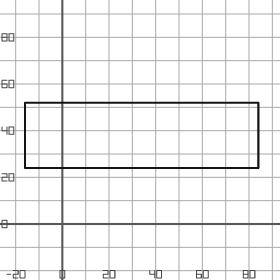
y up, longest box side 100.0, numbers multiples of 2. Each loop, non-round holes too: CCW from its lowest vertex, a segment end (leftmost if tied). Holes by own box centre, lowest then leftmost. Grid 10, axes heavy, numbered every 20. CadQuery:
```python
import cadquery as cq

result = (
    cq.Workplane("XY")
    .moveTo(-16.0, 24.0)
    .lineTo(84.0, 24.0)
    .lineTo(84.0, 52.0)
    .lineTo(-16.0, 52.0)
    .close()
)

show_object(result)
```